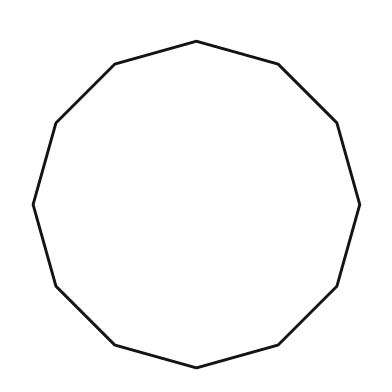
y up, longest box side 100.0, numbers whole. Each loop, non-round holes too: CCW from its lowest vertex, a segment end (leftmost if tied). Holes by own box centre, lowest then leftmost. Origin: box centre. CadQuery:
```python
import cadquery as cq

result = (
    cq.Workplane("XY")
    .moveTo(0.0, -50.0)
    .lineTo(25.0, -43.0)
    .lineTo(43.0, -25.0)
    .lineTo(50.0, 0.0)
    .lineTo(43.0, 25.0)
    .lineTo(25.0, 43.0)
    .lineTo(0.0, 50.0)
    .lineTo(-25.0, 43.0)
    .lineTo(-43.0, 25.0)
    .lineTo(-50.0, 0.0)
    .lineTo(-43.0, -25.0)
    .lineTo(-25.0, -43.0)
    .close()
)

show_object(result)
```